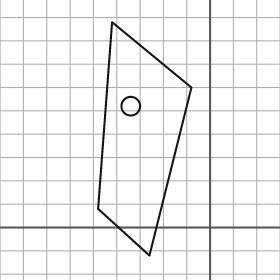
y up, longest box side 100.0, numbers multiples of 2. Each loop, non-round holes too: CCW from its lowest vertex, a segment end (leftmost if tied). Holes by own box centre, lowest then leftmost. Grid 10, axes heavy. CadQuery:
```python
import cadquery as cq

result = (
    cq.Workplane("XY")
    .moveTo(-26.0, -12.0)
    .lineTo(-8.0, 60.0)
    .lineTo(-42.0, 88.0)
    .lineTo(-48.0, 8.0)
    .close()
    .moveTo(-34.0, 52.0)
    .circle(4.0)
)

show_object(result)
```